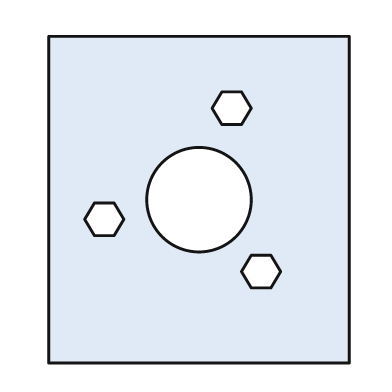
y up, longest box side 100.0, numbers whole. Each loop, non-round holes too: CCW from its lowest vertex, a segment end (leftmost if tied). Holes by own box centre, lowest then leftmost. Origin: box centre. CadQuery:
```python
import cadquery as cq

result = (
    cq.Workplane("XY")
    .moveTo(-46.0, -50.0)
    .lineTo(46.0, -50.0)
    .lineTo(46.0, 50.0)
    .lineTo(-46.0, 50.0)
    .close()
    .moveTo(16.0, -27.0)
    .lineTo(22.0, -27.0)
    .lineTo(25.0, -22.0)
    .lineTo(22.0, -17.0)
    .lineTo(16.0, -17.0)
    .lineTo(13.0, -22.0)
    .close()
    .moveTo(-32.0, -11.0)
    .lineTo(-26.0, -11.0)
    .lineTo(-23.0, -6.0)
    .lineTo(-26.0, -1.0)
    .lineTo(-32.0, -1.0)
    .lineTo(-35.0, -6.0)
    .close()
    .moveTo(0.0, 0.0)
    .circle(16.0)
    .moveTo(7.0, 23.0)
    .lineTo(13.0, 23.0)
    .lineTo(16.0, 28.0)
    .lineTo(13.0, 33.0)
    .lineTo(7.0, 33.0)
    .lineTo(4.0, 28.0)
    .close()
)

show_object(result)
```